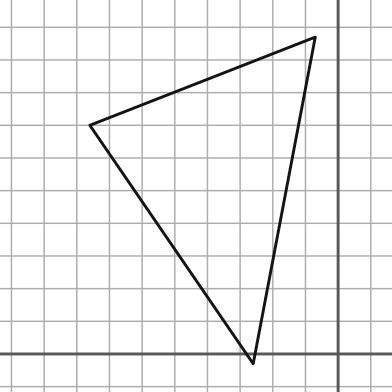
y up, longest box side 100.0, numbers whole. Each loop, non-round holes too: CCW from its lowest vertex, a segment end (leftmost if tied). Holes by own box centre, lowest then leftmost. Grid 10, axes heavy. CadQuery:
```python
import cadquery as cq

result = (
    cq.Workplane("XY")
    .moveTo(-26.0, -3.0)
    .lineTo(-7.0, 97.0)
    .lineTo(-76.0, 70.0)
    .close()
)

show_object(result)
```